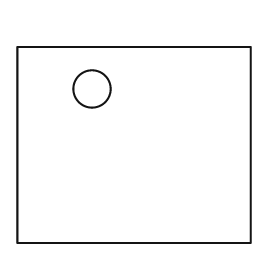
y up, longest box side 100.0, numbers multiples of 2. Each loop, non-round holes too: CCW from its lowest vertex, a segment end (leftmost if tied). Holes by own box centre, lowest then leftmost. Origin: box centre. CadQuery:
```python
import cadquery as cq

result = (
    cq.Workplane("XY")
    .moveTo(-50.0, -42.0)
    .lineTo(50.0, -42.0)
    .lineTo(50.0, 42.0)
    .lineTo(-50.0, 42.0)
    .close()
    .moveTo(-18.0, 24.0)
    .circle(8.0)
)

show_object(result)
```